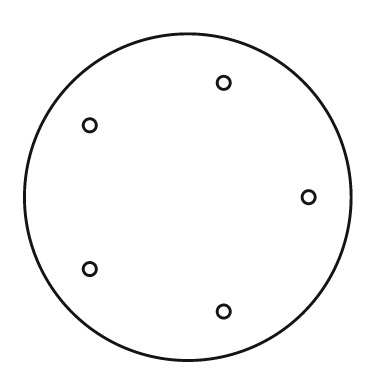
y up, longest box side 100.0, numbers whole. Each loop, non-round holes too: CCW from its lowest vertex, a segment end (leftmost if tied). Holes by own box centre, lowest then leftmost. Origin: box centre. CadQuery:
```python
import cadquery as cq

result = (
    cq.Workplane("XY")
    .moveTo(0.0, 0.0)
    .circle(50.0)
    .moveTo(11.0, -35.0)
    .circle(2.0)
    .moveTo(-30.0, -22.0)
    .circle(2.0)
    .moveTo(37.0, 0.0)
    .circle(2.0)
    .moveTo(-30.0, 22.0)
    .circle(2.0)
    .moveTo(11.0, 35.0)
    .circle(2.0)
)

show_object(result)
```